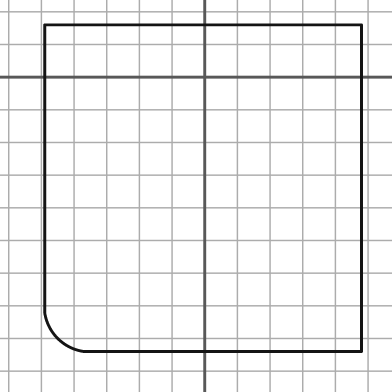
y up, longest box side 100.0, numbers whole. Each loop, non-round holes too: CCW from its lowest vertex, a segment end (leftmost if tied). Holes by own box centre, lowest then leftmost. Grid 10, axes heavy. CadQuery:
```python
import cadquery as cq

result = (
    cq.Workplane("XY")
    .moveTo(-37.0, -84.0)
    .lineTo(48.0, -84.0)
    .lineTo(48.0, 16.0)
    .lineTo(-49.0, 16.0)
    .lineTo(-49.0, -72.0)
    .threePointArc((-45.0, -80.0), (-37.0, -84.0))
    .close()
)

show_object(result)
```